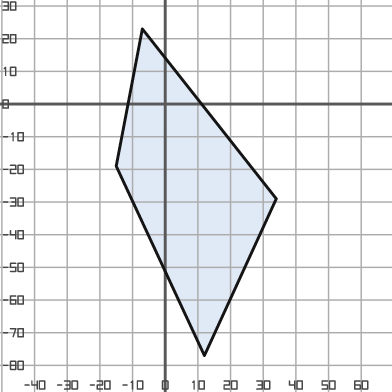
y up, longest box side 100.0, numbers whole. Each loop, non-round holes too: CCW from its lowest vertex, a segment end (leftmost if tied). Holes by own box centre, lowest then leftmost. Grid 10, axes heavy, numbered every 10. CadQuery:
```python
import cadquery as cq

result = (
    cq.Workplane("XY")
    .moveTo(12.0, -77.0)
    .lineTo(34.0, -29.0)
    .lineTo(-7.0, 23.0)
    .lineTo(-15.0, -19.0)
    .close()
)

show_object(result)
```